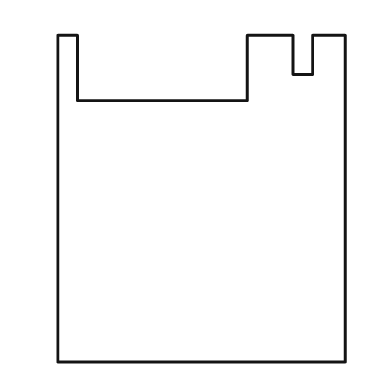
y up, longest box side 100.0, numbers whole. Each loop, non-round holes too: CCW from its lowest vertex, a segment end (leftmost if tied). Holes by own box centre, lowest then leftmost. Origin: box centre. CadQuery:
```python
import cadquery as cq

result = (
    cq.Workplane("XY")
    .moveTo(-44.0, -50.0)
    .lineTo(44.0, -50.0)
    .lineTo(44.0, 50.0)
    .lineTo(34.0, 50.0)
    .lineTo(34.0, 38.0)
    .lineTo(28.0, 38.0)
    .lineTo(28.0, 50.0)
    .lineTo(14.0, 50.0)
    .lineTo(14.0, 30.0)
    .lineTo(-38.0, 30.0)
    .lineTo(-38.0, 50.0)
    .lineTo(-44.0, 50.0)
    .close()
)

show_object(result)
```